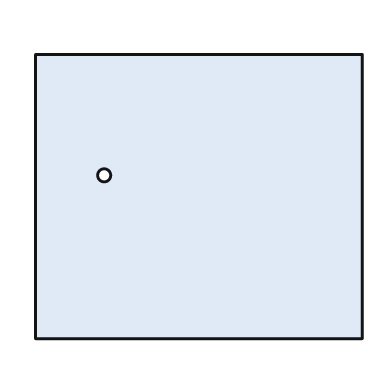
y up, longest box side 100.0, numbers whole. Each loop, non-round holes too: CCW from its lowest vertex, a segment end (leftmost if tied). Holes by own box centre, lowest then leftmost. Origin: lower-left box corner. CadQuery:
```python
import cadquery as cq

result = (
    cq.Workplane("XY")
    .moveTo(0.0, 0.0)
    .lineTo(100.0, 0.0)
    .lineTo(100.0, 87.0)
    .lineTo(0.0, 87.0)
    .close()
    .moveTo(21.0, 50.0)
    .circle(2.0)
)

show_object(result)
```